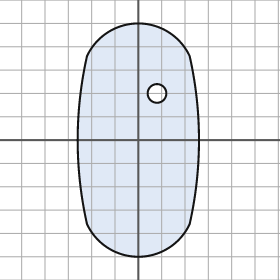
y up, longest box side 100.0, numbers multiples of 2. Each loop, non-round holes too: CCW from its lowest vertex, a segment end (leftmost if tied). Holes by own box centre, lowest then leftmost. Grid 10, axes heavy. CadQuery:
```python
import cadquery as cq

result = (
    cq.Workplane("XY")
    .moveTo(-22.0, -36.0)
    .threePointArc((0.0, -50.0), (22.0, -36.0))
    .threePointArc((26.0, 0.0), (22.0, 36.0))
    .threePointArc((0.0, 50.0), (-22.0, 36.0))
    .threePointArc((-26.0, 0.0), (-22.0, -36.0))
    .close()
    .moveTo(8.0, 20.0)
    .circle(4.0)
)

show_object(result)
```